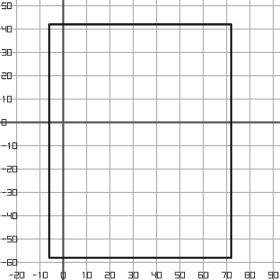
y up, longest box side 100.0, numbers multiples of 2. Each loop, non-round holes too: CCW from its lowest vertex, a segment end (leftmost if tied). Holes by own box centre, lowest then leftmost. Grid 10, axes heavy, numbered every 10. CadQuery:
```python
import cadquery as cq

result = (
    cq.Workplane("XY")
    .moveTo(-6.0, -58.0)
    .lineTo(72.0, -58.0)
    .lineTo(72.0, 42.0)
    .lineTo(-6.0, 42.0)
    .close()
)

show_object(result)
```